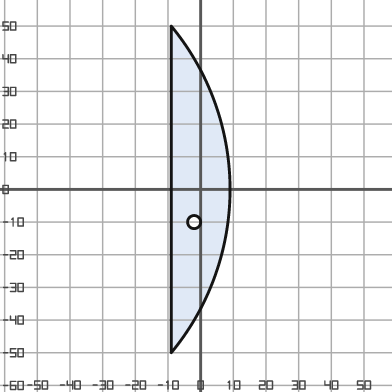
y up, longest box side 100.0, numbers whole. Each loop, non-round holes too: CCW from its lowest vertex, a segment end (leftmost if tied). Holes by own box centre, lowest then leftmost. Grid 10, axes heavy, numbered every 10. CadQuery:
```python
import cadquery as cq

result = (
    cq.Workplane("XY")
    .moveTo(-9.0, -50.0)
    .threePointArc((9.0, 0.0), (-9.0, 50.0))
    .close()
    .moveTo(-2.0, -10.0)
    .circle(2.0)
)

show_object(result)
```